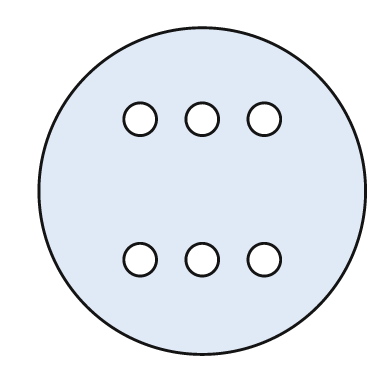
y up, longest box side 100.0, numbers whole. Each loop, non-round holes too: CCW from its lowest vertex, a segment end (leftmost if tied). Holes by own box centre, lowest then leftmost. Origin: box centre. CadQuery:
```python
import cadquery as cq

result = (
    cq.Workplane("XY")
    .moveTo(0.0, 0.0)
    .circle(50.0)
    .moveTo(-19.0, -21.0)
    .circle(5.0)
    .moveTo(0.0, -21.0)
    .circle(5.0)
    .moveTo(19.0, -21.0)
    .circle(5.0)
    .moveTo(-19.0, 22.0)
    .circle(5.0)
    .moveTo(0.0, 22.0)
    .circle(5.0)
    .moveTo(19.0, 22.0)
    .circle(5.0)
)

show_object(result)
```